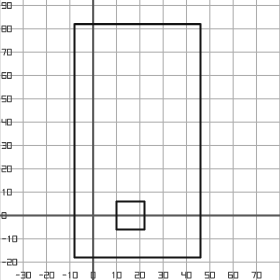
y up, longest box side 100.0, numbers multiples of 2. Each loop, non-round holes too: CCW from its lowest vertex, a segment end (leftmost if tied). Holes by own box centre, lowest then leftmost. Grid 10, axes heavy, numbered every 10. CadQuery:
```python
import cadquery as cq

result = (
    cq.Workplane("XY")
    .moveTo(-8.0, -18.0)
    .lineTo(46.0, -18.0)
    .lineTo(46.0, 82.0)
    .lineTo(-8.0, 82.0)
    .close()
    .moveTo(10.0, -6.0)
    .lineTo(22.0, -6.0)
    .lineTo(22.0, 6.0)
    .lineTo(10.0, 6.0)
    .close()
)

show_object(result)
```